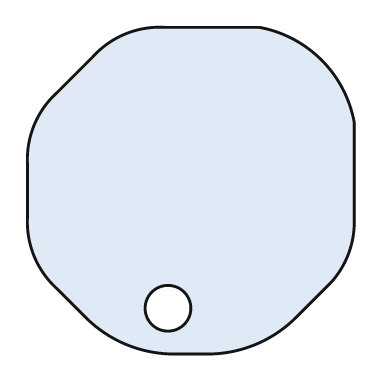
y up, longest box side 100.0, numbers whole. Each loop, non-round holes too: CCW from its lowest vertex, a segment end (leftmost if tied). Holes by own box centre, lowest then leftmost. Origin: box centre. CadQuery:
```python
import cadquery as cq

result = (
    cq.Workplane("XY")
    .moveTo(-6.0, -50.0)
    .lineTo(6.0, -50.0)
    .threePointArc((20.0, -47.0), (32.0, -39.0))
    .lineTo(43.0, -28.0)
    .threePointArc((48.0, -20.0), (50.0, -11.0))
    .lineTo(50.0, 21.0)
    .threePointArc((40.0, 40.0), (21.0, 50.0))
    .lineTo(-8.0, 50.0)
    .threePointArc((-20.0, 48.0), (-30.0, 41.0))
    .lineTo(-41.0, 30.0)
    .threePointArc((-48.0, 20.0), (-50.0, 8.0))
    .lineTo(-50.0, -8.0)
    .threePointArc((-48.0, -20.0), (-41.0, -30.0))
    .lineTo(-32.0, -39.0)
    .threePointArc((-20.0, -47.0), (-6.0, -50.0))
    .close()
    .moveTo(-7.0, -36.0)
    .circle(7.0)
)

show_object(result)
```